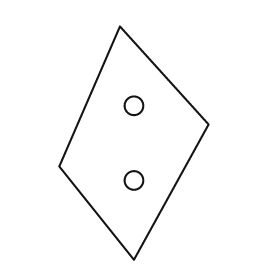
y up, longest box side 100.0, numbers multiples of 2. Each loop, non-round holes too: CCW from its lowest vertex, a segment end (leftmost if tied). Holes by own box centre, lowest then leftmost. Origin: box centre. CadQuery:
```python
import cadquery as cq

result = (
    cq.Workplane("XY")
    .moveTo(0.0, -50.0)
    .lineTo(32.0, 8.0)
    .lineTo(-6.0, 50.0)
    .lineTo(-32.0, -10.0)
    .close()
    .moveTo(0.0, -16.0)
    .circle(4.0)
    .moveTo(0.0, 16.0)
    .circle(4.0)
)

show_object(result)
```